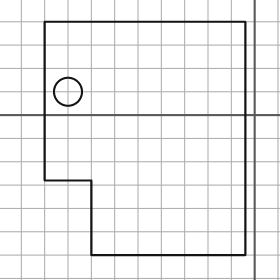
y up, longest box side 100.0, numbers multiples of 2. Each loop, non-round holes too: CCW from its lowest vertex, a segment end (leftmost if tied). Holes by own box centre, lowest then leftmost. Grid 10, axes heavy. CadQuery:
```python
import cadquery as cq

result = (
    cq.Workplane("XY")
    .moveTo(-70.0, -60.0)
    .lineTo(-4.0, -60.0)
    .lineTo(-4.0, 40.0)
    .lineTo(-90.0, 40.0)
    .lineTo(-90.0, -28.0)
    .lineTo(-70.0, -28.0)
    .close()
    .moveTo(-80.0, 10.0)
    .circle(6.0)
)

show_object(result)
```